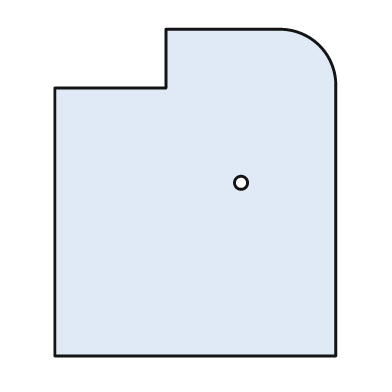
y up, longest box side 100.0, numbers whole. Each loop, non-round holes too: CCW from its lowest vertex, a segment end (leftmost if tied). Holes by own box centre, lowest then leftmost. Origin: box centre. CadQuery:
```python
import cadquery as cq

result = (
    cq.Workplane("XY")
    .moveTo(-43.0, -50.0)
    .lineTo(43.0, -50.0)
    .lineTo(43.0, 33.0)
    .threePointArc((38.0, 45.0), (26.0, 50.0))
    .lineTo(-9.0, 50.0)
    .lineTo(-9.0, 32.0)
    .lineTo(-43.0, 32.0)
    .close()
    .moveTo(14.0, 3.0)
    .circle(2.0)
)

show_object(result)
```